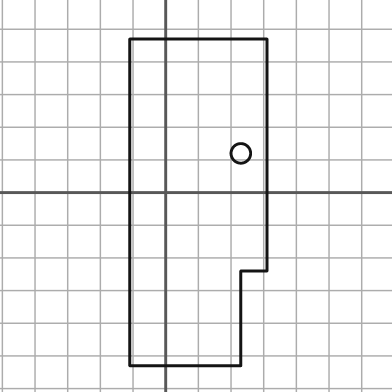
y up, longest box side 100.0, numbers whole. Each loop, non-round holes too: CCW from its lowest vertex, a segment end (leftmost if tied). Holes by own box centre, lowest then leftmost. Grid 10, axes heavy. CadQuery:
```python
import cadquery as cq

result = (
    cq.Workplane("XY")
    .moveTo(-11.0, -53.0)
    .lineTo(23.0, -53.0)
    .lineTo(23.0, -24.0)
    .lineTo(31.0, -24.0)
    .lineTo(31.0, 47.0)
    .lineTo(-11.0, 47.0)
    .close()
    .moveTo(23.0, 12.0)
    .circle(3.0)
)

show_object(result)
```